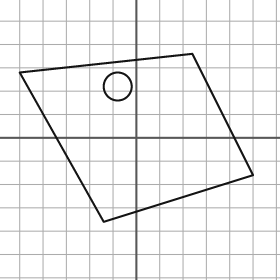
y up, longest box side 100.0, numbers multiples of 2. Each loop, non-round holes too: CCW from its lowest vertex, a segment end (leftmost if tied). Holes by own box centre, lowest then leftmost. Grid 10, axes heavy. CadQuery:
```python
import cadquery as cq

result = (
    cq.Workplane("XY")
    .moveTo(-14.0, -36.0)
    .lineTo(50.0, -16.0)
    .lineTo(24.0, 36.0)
    .lineTo(-50.0, 28.0)
    .close()
    .moveTo(-8.0, 22.0)
    .circle(6.0)
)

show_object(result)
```